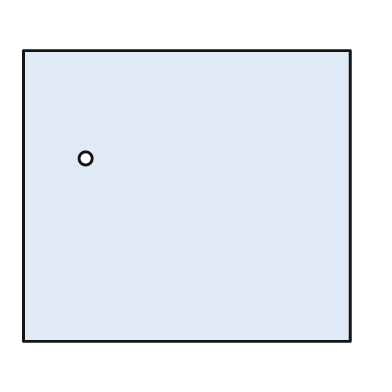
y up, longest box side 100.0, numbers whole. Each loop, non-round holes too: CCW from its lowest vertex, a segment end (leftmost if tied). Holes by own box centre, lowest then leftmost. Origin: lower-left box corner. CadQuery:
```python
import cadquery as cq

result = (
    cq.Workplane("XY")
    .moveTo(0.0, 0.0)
    .lineTo(100.0, 0.0)
    .lineTo(100.0, 89.0)
    .lineTo(0.0, 89.0)
    .close()
    .moveTo(19.0, 56.0)
    .circle(2.0)
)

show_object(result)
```